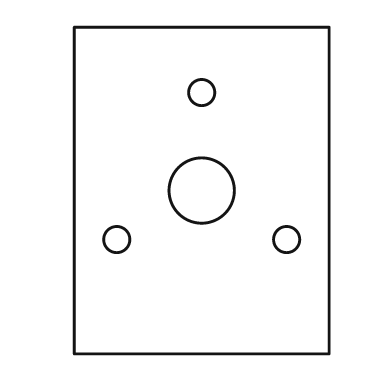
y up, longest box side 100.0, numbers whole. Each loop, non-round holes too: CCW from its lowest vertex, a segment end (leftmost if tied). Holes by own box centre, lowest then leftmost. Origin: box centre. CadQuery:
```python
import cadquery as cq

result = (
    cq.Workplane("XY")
    .moveTo(-39.0, -50.0)
    .lineTo(39.0, -50.0)
    .lineTo(39.0, 50.0)
    .lineTo(-39.0, 50.0)
    .close()
    .moveTo(-26.0, -15.0)
    .circle(4.0)
    .moveTo(26.0, -15.0)
    .circle(4.0)
    .moveTo(0.0, 0.0)
    .circle(10.0)
    .moveTo(0.0, 30.0)
    .circle(4.0)
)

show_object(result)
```